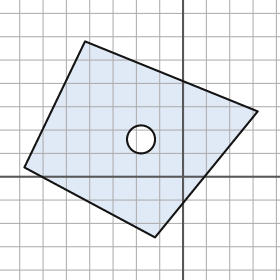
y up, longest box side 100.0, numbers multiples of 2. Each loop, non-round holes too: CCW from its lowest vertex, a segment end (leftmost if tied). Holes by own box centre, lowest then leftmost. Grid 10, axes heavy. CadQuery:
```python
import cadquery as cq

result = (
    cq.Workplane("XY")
    .moveTo(-12.0, -26.0)
    .lineTo(32.0, 28.0)
    .lineTo(-42.0, 58.0)
    .lineTo(-68.0, 4.0)
    .close()
    .moveTo(-18.0, 16.0)
    .circle(6.0)
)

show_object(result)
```